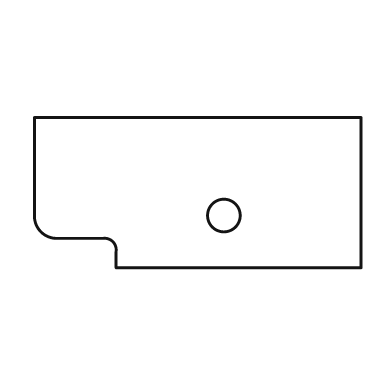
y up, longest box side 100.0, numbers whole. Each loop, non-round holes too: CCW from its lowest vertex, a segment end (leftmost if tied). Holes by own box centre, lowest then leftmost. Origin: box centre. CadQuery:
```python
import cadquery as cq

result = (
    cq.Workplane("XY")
    .moveTo(-25.0, -23.0)
    .lineTo(50.0, -23.0)
    .lineTo(50.0, 23.0)
    .lineTo(-50.0, 23.0)
    .lineTo(-50.0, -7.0)
    .threePointArc((-48.0, -12.0), (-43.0, -14.0))
    .lineTo(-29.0, -14.0)
    .threePointArc((-26.0, -15.0), (-25.0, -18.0))
    .close()
    .moveTo(8.0, -7.0)
    .circle(5.0)
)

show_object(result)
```